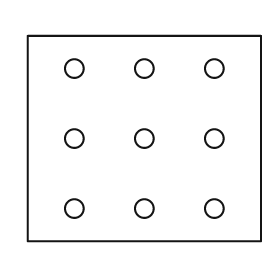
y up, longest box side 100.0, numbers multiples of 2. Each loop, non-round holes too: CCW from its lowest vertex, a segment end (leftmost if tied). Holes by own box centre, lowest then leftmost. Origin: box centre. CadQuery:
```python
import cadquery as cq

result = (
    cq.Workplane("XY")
    .moveTo(-50.0, -44.0)
    .lineTo(50.0, -44.0)
    .lineTo(50.0, 44.0)
    .lineTo(-50.0, 44.0)
    .close()
    .moveTo(-30.0, -30.0)
    .circle(4.0)
    .moveTo(0.0, -30.0)
    .circle(4.0)
    .moveTo(30.0, -30.0)
    .circle(4.0)
    .moveTo(-30.0, 0.0)
    .circle(4.0)
    .moveTo(0.0, 0.0)
    .circle(4.0)
    .moveTo(30.0, 0.0)
    .circle(4.0)
    .moveTo(-30.0, 30.0)
    .circle(4.0)
    .moveTo(0.0, 30.0)
    .circle(4.0)
    .moveTo(30.0, 30.0)
    .circle(4.0)
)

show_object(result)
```